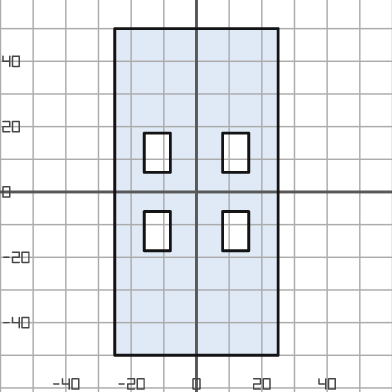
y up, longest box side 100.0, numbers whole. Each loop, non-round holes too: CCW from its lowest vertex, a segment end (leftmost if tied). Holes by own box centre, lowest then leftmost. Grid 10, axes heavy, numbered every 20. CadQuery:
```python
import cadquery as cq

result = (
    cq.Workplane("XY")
    .moveTo(-25.0, -50.0)
    .lineTo(25.0, -50.0)
    .lineTo(25.0, 50.0)
    .lineTo(-25.0, 50.0)
    .close()
    .moveTo(-16.0, -18.0)
    .lineTo(-8.0, -18.0)
    .lineTo(-8.0, -6.0)
    .lineTo(-16.0, -6.0)
    .close()
    .moveTo(8.0, -18.0)
    .lineTo(16.0, -18.0)
    .lineTo(16.0, -6.0)
    .lineTo(8.0, -6.0)
    .close()
    .moveTo(-16.0, 6.0)
    .lineTo(-8.0, 6.0)
    .lineTo(-8.0, 18.0)
    .lineTo(-16.0, 18.0)
    .close()
    .moveTo(8.0, 6.0)
    .lineTo(16.0, 6.0)
    .lineTo(16.0, 18.0)
    .lineTo(8.0, 18.0)
    .close()
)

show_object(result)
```